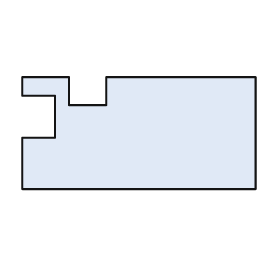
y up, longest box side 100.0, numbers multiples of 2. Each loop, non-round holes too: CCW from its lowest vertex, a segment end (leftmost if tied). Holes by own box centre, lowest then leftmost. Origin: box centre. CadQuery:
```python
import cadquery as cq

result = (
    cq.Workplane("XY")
    .moveTo(-50.0, -24.0)
    .lineTo(50.0, -24.0)
    .lineTo(50.0, 24.0)
    .lineTo(-14.0, 24.0)
    .lineTo(-14.0, 12.0)
    .lineTo(-30.0, 12.0)
    .lineTo(-30.0, 24.0)
    .lineTo(-50.0, 24.0)
    .lineTo(-50.0, 16.0)
    .lineTo(-36.0, 16.0)
    .lineTo(-36.0, -2.0)
    .lineTo(-50.0, -2.0)
    .close()
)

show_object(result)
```